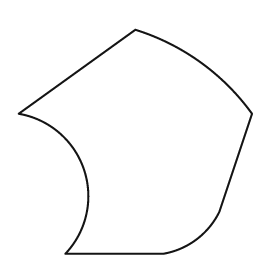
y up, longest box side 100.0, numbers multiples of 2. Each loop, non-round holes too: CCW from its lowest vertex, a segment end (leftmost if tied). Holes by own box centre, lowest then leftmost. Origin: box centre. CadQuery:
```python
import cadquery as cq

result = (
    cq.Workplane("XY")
    .moveTo(-30.0, -48.0)
    .lineTo(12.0, -48.0)
    .threePointArc((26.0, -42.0), (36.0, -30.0))
    .lineTo(50.0, 12.0)
    .threePointArc((28.0, 34.0), (0.0, 48.0))
    .lineTo(-50.0, 12.0)
    .threePointArc((-22.0, -12.0), (-30.0, -48.0))
    .close()
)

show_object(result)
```